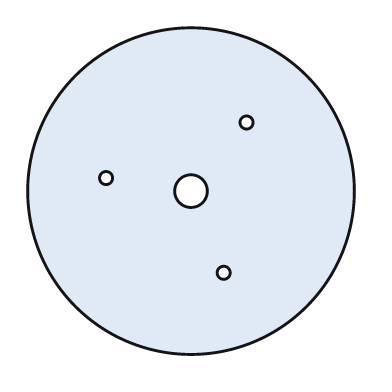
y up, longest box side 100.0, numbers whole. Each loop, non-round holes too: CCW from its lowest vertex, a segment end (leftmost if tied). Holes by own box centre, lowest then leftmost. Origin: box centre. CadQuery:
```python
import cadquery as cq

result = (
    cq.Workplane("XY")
    .moveTo(0.0, 0.0)
    .circle(50.0)
    .moveTo(10.0, -25.0)
    .circle(2.0)
    .moveTo(0.0, 0.0)
    .circle(5.0)
    .moveTo(-26.0, 4.0)
    .circle(2.0)
    .moveTo(17.0, 21.0)
    .circle(2.0)
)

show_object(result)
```